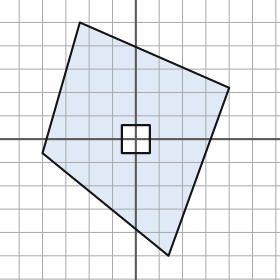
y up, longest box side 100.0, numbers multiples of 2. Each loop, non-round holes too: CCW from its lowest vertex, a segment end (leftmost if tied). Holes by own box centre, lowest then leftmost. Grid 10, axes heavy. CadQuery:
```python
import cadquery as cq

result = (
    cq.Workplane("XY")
    .moveTo(14.0, -50.0)
    .lineTo(40.0, 22.0)
    .lineTo(-24.0, 50.0)
    .lineTo(-40.0, -6.0)
    .close()
    .moveTo(-6.0, -6.0)
    .lineTo(6.0, -6.0)
    .lineTo(6.0, 6.0)
    .lineTo(-6.0, 6.0)
    .close()
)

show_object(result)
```